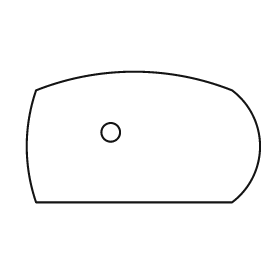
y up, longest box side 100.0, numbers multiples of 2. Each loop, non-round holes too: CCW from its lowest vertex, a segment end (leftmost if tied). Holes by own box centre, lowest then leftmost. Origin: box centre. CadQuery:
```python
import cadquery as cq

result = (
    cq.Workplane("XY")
    .moveTo(-46.0, -28.0)
    .lineTo(38.0, -28.0)
    .threePointArc((50.0, -4.0), (38.0, 20.0))
    .threePointArc((-4.0, 28.0), (-46.0, 20.0))
    .threePointArc((-50.0, -4.0), (-46.0, -28.0))
    .close()
    .moveTo(-14.0, 2.0)
    .circle(4.0)
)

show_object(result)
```